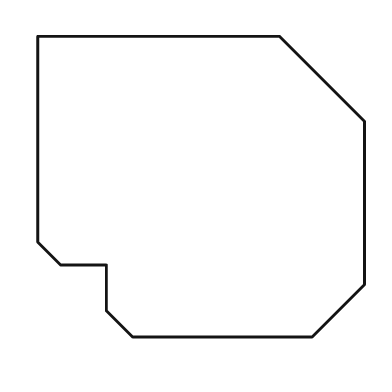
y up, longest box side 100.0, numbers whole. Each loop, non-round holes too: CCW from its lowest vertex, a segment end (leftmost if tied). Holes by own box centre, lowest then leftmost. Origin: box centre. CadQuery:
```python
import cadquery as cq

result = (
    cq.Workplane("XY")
    .moveTo(-21.0, -46.0)
    .lineTo(34.0, -46.0)
    .lineTo(50.0, -30.0)
    .lineTo(50.0, 20.0)
    .lineTo(24.0, 46.0)
    .lineTo(-50.0, 46.0)
    .lineTo(-50.0, -17.0)
    .lineTo(-43.0, -24.0)
    .lineTo(-29.0, -24.0)
    .lineTo(-29.0, -38.0)
    .close()
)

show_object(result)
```